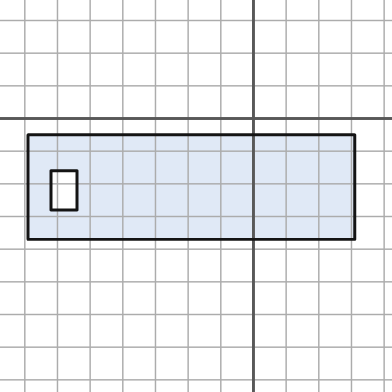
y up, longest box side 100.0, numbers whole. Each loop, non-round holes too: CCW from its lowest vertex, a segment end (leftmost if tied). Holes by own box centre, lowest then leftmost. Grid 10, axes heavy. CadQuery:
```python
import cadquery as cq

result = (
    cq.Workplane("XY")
    .moveTo(-69.0, -37.0)
    .lineTo(31.0, -37.0)
    .lineTo(31.0, -5.0)
    .lineTo(-69.0, -5.0)
    .close()
    .moveTo(-62.0, -28.0)
    .lineTo(-54.0, -28.0)
    .lineTo(-54.0, -16.0)
    .lineTo(-62.0, -16.0)
    .close()
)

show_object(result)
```